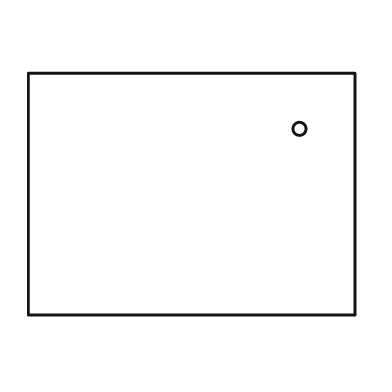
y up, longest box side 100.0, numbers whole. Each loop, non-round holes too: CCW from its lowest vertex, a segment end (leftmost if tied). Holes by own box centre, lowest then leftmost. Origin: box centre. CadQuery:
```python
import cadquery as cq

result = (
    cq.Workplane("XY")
    .moveTo(-50.0, -37.0)
    .lineTo(50.0, -37.0)
    .lineTo(50.0, 37.0)
    .lineTo(-50.0, 37.0)
    .close()
    .moveTo(33.0, 20.0)
    .circle(2.0)
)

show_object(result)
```